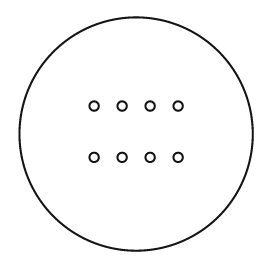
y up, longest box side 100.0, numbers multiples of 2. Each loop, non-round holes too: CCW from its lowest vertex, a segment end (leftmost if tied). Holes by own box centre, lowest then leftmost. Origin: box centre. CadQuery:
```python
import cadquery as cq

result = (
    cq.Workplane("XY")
    .moveTo(0.0, 0.0)
    .circle(50.0)
    .moveTo(-18.0, -10.0)
    .circle(2.0)
    .moveTo(-6.0, -10.0)
    .circle(2.0)
    .moveTo(6.0, -10.0)
    .circle(2.0)
    .moveTo(18.0, -10.0)
    .circle(2.0)
    .moveTo(-18.0, 12.0)
    .circle(2.0)
    .moveTo(-6.0, 12.0)
    .circle(2.0)
    .moveTo(6.0, 12.0)
    .circle(2.0)
    .moveTo(18.0, 12.0)
    .circle(2.0)
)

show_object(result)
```